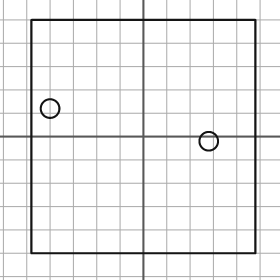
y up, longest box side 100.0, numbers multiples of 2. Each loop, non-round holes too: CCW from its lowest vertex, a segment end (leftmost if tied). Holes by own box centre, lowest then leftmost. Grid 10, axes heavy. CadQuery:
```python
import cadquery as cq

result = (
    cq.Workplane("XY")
    .moveTo(-48.0, -50.0)
    .lineTo(48.0, -50.0)
    .lineTo(48.0, 50.0)
    .lineTo(-48.0, 50.0)
    .close()
    .moveTo(28.0, -2.0)
    .circle(4.0)
    .moveTo(-40.0, 12.0)
    .circle(4.0)
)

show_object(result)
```